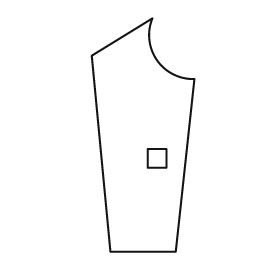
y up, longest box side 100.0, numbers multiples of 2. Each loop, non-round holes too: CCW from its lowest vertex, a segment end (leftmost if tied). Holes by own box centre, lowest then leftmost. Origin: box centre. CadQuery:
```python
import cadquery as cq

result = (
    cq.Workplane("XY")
    .moveTo(-14.0, -50.0)
    .lineTo(14.0, -50.0)
    .lineTo(22.0, 24.0)
    .threePointArc((6.0, 32.0), (4.0, 50.0))
    .lineTo(-22.0, 34.0)
    .close()
    .moveTo(2.0, -14.0)
    .lineTo(10.0, -14.0)
    .lineTo(10.0, -6.0)
    .lineTo(2.0, -6.0)
    .close()
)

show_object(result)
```